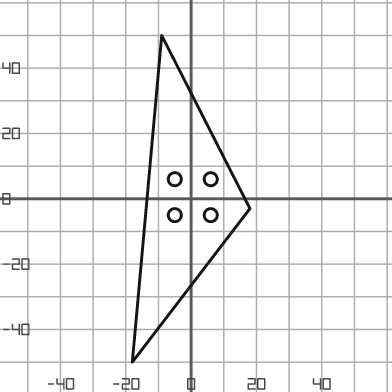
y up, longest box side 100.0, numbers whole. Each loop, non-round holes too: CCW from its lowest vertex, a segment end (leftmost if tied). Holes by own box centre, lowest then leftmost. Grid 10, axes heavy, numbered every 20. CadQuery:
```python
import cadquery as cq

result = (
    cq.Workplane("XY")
    .moveTo(-18.0, -50.0)
    .lineTo(18.0, -3.0)
    .lineTo(-9.0, 50.0)
    .close()
    .moveTo(-5.0, -5.0)
    .circle(2.0)
    .moveTo(6.0, -5.0)
    .circle(2.0)
    .moveTo(-5.0, 6.0)
    .circle(2.0)
    .moveTo(6.0, 6.0)
    .circle(2.0)
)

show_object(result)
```